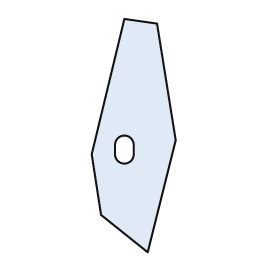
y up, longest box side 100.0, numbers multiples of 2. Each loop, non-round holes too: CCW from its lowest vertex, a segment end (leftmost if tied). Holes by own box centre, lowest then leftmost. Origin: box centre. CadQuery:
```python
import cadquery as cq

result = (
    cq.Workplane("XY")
    .moveTo(6.0, -50.0)
    .lineTo(18.0, -2.0)
    .lineTo(10.0, 48.0)
    .lineTo(-4.0, 50.0)
    .lineTo(-18.0, -8.0)
    .lineTo(-14.0, -34.0)
    .close()
    .moveTo(-8.0, -8.0)
    .threePointArc((-4.0, -12.0), (0.0, -8.0))
    .lineTo(0.0, -4.0)
    .threePointArc((-4.0, 0.0), (-8.0, -4.0))
    .close()
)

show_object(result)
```